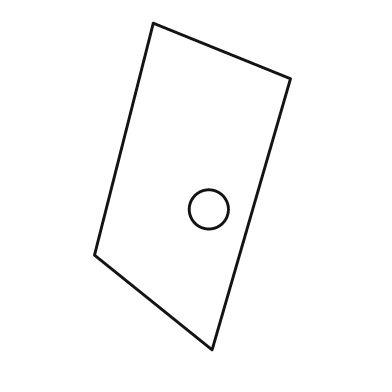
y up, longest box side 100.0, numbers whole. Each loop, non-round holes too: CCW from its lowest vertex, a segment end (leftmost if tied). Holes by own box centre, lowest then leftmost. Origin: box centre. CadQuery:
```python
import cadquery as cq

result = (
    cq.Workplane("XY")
    .moveTo(6.0, -50.0)
    .lineTo(30.0, 33.0)
    .lineTo(-12.0, 50.0)
    .lineTo(-30.0, -21.0)
    .close()
    .moveTo(5.0, -7.0)
    .circle(6.0)
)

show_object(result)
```